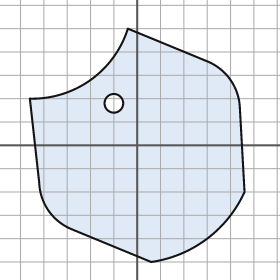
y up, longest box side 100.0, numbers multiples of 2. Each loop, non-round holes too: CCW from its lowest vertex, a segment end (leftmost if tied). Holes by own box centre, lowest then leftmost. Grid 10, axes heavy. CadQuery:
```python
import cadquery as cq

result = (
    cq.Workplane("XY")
    .moveTo(6.0, -50.0)
    .threePointArc((30.0, -40.0), (46.0, -20.0))
    .lineTo(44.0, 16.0)
    .threePointArc((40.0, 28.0), (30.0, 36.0))
    .lineTo(-4.0, 50.0)
    .threePointArc((-20.0, 28.0), (-46.0, 20.0))
    .lineTo(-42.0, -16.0)
    .threePointArc((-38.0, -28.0), (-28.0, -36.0))
    .close()
    .moveTo(-10.0, 18.0)
    .circle(4.0)
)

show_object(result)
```